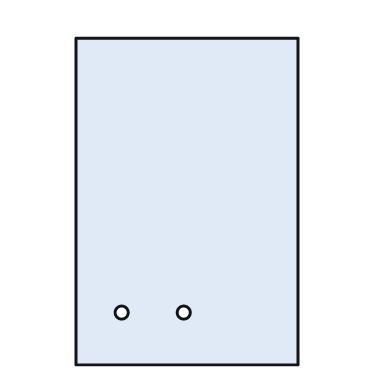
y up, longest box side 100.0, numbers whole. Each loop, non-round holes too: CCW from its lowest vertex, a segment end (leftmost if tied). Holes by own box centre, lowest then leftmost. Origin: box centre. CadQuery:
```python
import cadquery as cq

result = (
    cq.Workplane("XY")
    .moveTo(-34.0, -50.0)
    .lineTo(34.0, -50.0)
    .lineTo(34.0, 50.0)
    .lineTo(-34.0, 50.0)
    .close()
    .moveTo(-20.0, -34.0)
    .circle(2.0)
    .moveTo(-1.0, -34.0)
    .circle(2.0)
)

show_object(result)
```